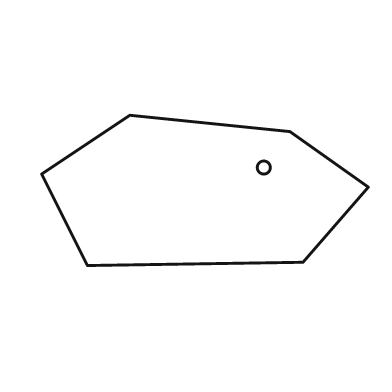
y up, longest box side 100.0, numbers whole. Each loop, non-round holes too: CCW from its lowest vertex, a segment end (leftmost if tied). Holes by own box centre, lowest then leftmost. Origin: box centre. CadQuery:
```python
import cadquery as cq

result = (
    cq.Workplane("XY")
    .moveTo(-36.0, -23.0)
    .lineTo(30.0, -22.0)
    .lineTo(50.0, 1.0)
    .lineTo(26.0, 18.0)
    .lineTo(-23.0, 23.0)
    .lineTo(-50.0, 5.0)
    .close()
    .moveTo(18.0, 7.0)
    .circle(2.0)
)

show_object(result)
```